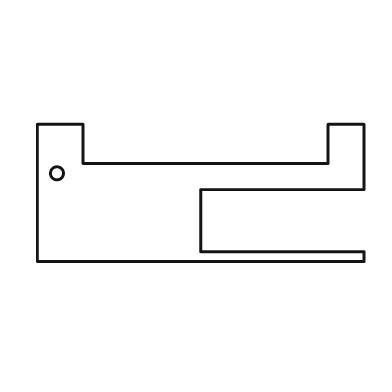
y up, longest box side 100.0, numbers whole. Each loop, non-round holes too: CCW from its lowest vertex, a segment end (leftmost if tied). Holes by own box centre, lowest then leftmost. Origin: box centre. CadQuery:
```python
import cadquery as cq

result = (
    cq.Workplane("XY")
    .moveTo(-50.0, -21.0)
    .lineTo(50.0, -21.0)
    .lineTo(50.0, -18.0)
    .lineTo(0.0, -18.0)
    .lineTo(0.0, 1.0)
    .lineTo(50.0, 1.0)
    .lineTo(50.0, 21.0)
    .lineTo(39.0, 21.0)
    .lineTo(39.0, 9.0)
    .lineTo(-36.0, 9.0)
    .lineTo(-36.0, 21.0)
    .lineTo(-50.0, 21.0)
    .close()
    .moveTo(-44.0, 6.0)
    .circle(2.0)
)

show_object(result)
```